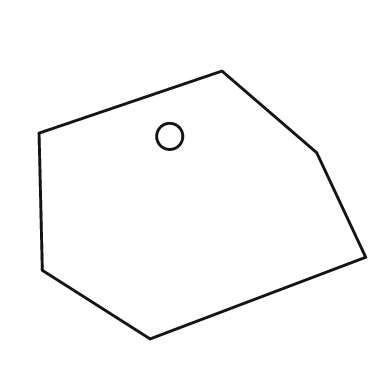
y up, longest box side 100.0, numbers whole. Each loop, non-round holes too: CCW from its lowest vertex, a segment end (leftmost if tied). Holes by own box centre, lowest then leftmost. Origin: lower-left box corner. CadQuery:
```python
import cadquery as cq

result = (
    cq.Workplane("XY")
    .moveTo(34.0, 0.0)
    .lineTo(100.0, 25.0)
    .lineTo(85.0, 57.0)
    .lineTo(56.0, 82.0)
    .lineTo(0.0, 63.0)
    .lineTo(1.0, 21.0)
    .close()
    .moveTo(40.0, 62.0)
    .circle(4.0)
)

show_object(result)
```